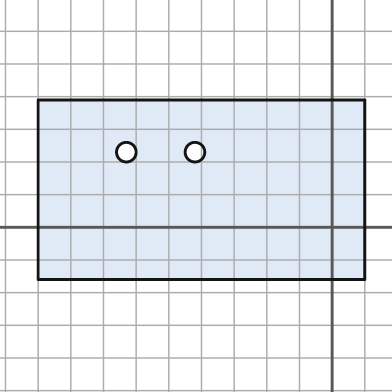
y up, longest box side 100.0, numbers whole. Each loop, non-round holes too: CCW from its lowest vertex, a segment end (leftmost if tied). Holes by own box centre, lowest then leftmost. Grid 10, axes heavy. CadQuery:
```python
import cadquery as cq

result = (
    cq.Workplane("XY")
    .moveTo(-90.0, -16.0)
    .lineTo(10.0, -16.0)
    .lineTo(10.0, 39.0)
    .lineTo(-90.0, 39.0)
    .close()
    .moveTo(-63.0, 23.0)
    .circle(3.0)
    .moveTo(-42.0, 23.0)
    .circle(3.0)
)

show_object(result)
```